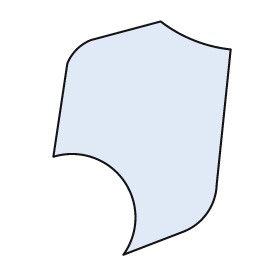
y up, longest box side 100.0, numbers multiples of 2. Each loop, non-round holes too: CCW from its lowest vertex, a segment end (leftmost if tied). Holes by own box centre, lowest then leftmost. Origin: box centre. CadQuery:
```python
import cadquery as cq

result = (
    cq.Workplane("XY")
    .moveTo(-8.0, -50.0)
    .lineTo(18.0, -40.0)
    .threePointArc((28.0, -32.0), (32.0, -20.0))
    .lineTo(38.0, 38.0)
    .threePointArc((22.0, 42.0), (8.0, 50.0))
    .lineTo(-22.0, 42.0)
    .threePointArc((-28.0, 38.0), (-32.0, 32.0))
    .lineTo(-38.0, -8.0)
    .threePointArc((-8.0, -18.0), (-8.0, -50.0))
    .close()
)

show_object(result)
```